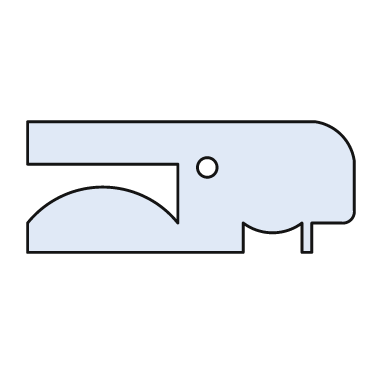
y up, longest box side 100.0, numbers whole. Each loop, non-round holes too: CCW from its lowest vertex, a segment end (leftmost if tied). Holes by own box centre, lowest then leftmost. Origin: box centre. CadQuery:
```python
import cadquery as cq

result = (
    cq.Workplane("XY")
    .moveTo(-50.0, -20.0)
    .lineTo(16.0, -20.0)
    .lineTo(16.0, -11.0)
    .threePointArc((25.0, -14.0), (34.0, -11.0))
    .lineTo(34.0, -20.0)
    .lineTo(37.0, -20.0)
    .lineTo(37.0, -11.0)
    .lineTo(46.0, -11.0)
    .threePointArc((49.0, -10.0), (50.0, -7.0))
    .lineTo(50.0, 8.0)
    .threePointArc((46.0, 16.0), (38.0, 20.0))
    .lineTo(-50.0, 20.0)
    .lineTo(-50.0, 7.0)
    .lineTo(-4.0, 7.0)
    .lineTo(-4.0, -11.0)
    .threePointArc((-27.0, 0.0), (-50.0, -11.0))
    .close()
    .moveTo(5.0, 6.0)
    .circle(3.0)
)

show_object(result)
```